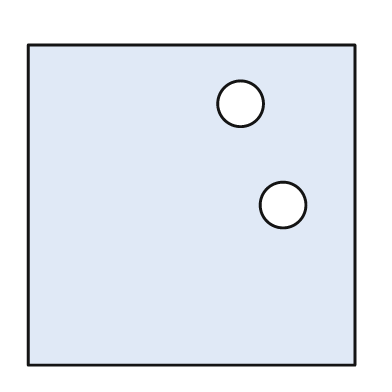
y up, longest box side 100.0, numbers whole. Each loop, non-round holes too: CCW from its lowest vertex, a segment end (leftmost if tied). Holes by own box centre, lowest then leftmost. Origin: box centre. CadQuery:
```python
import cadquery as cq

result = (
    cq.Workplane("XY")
    .moveTo(-50.0, -49.0)
    .lineTo(50.0, -49.0)
    .lineTo(50.0, 49.0)
    .lineTo(-50.0, 49.0)
    .close()
    .moveTo(28.0, 0.0)
    .circle(7.0)
    .moveTo(15.0, 31.0)
    .circle(7.0)
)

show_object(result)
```